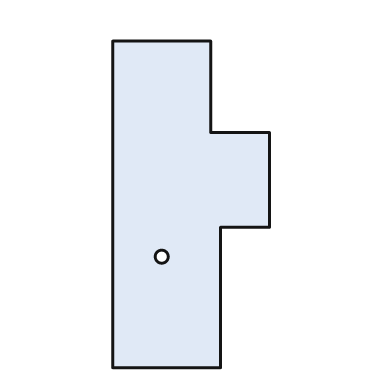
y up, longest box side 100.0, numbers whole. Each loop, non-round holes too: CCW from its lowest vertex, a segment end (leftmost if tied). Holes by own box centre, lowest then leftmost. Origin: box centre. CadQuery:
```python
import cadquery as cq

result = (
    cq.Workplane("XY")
    .moveTo(-24.0, -50.0)
    .lineTo(9.0, -50.0)
    .lineTo(9.0, -7.0)
    .lineTo(24.0, -7.0)
    .lineTo(24.0, 22.0)
    .lineTo(6.0, 22.0)
    .lineTo(6.0, 50.0)
    .lineTo(-24.0, 50.0)
    .close()
    .moveTo(-9.0, -16.0)
    .circle(2.0)
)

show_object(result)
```